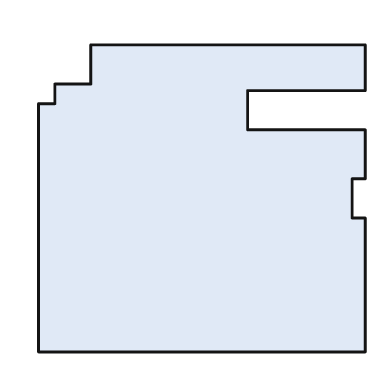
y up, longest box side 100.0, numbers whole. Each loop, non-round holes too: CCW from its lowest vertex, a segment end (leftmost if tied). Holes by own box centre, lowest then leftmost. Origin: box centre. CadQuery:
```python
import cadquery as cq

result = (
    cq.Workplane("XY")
    .moveTo(-50.0, -47.0)
    .lineTo(50.0, -47.0)
    .lineTo(50.0, -6.0)
    .lineTo(46.0, -6.0)
    .lineTo(46.0, 6.0)
    .lineTo(50.0, 6.0)
    .lineTo(50.0, 21.0)
    .lineTo(14.0, 21.0)
    .lineTo(14.0, 33.0)
    .lineTo(50.0, 33.0)
    .lineTo(50.0, 47.0)
    .lineTo(-34.0, 47.0)
    .lineTo(-34.0, 35.0)
    .lineTo(-45.0, 35.0)
    .lineTo(-45.0, 29.0)
    .lineTo(-50.0, 29.0)
    .close()
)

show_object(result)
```